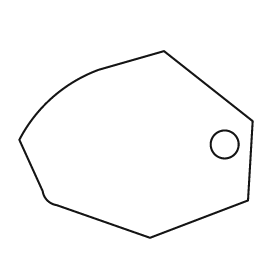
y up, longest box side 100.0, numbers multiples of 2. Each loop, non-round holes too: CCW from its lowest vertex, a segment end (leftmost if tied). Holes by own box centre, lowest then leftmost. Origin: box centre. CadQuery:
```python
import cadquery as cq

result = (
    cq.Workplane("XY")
    .moveTo(6.0, -40.0)
    .lineTo(48.0, -24.0)
    .lineTo(50.0, 10.0)
    .lineTo(12.0, 40.0)
    .lineTo(-16.0, 32.0)
    .threePointArc((-36.0, 20.0), (-50.0, 2.0))
    .lineTo(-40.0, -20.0)
    .threePointArc((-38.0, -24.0), (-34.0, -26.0))
    .close()
    .moveTo(38.0, 0.0)
    .circle(6.0)
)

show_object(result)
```